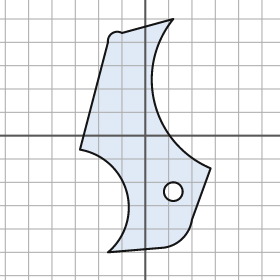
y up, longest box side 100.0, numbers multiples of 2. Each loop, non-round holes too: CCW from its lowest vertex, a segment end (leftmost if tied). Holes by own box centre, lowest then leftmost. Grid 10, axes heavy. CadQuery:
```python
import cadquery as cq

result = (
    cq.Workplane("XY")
    .moveTo(-16.0, -50.0)
    .lineTo(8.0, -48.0)
    .threePointArc((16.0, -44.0), (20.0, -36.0))
    .lineTo(28.0, -14.0)
    .threePointArc((4.0, 14.0), (12.0, 50.0))
    .lineTo(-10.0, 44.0)
    .threePointArc((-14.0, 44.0), (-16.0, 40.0))
    .lineTo(-28.0, -6.0)
    .threePointArc((-8.0, -24.0), (-16.0, -50.0))
    .close()
    .moveTo(12.0, -24.0)
    .circle(4.0)
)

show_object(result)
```